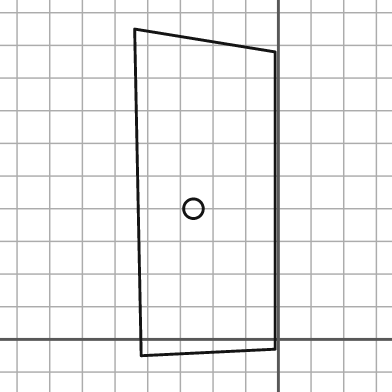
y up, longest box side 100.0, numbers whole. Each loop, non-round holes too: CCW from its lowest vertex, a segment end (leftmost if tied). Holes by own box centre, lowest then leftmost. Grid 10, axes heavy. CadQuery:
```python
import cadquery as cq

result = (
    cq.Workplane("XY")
    .moveTo(-42.0, -5.0)
    .lineTo(-1.0, -3.0)
    .lineTo(-1.0, 88.0)
    .lineTo(-44.0, 95.0)
    .close()
    .moveTo(-26.0, 40.0)
    .circle(3.0)
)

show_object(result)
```